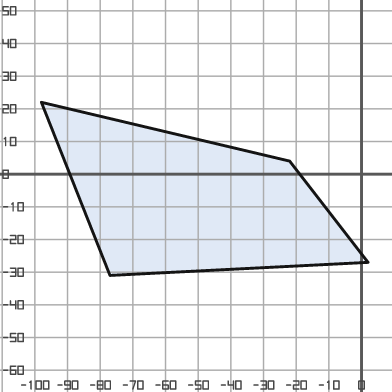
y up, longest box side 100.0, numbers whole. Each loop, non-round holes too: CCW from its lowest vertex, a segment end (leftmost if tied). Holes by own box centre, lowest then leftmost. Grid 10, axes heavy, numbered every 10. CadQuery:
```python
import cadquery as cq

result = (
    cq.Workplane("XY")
    .moveTo(-77.0, -31.0)
    .lineTo(2.0, -27.0)
    .lineTo(-22.0, 4.0)
    .lineTo(-98.0, 22.0)
    .close()
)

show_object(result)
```